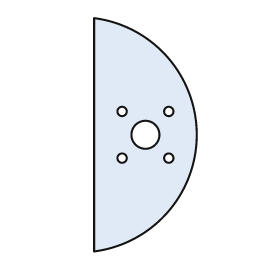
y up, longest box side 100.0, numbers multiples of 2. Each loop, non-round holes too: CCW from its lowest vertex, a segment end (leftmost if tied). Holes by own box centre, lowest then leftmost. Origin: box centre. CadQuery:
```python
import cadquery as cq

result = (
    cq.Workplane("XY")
    .moveTo(-22.0, -50.0)
    .threePointArc((22.0, 0.0), (-22.0, 50.0))
    .close()
    .moveTo(-10.0, -10.0)
    .circle(2.0)
    .moveTo(10.0, -10.0)
    .circle(2.0)
    .moveTo(0.0, 0.0)
    .circle(6.0)
    .moveTo(-10.0, 10.0)
    .circle(2.0)
    .moveTo(10.0, 10.0)
    .circle(2.0)
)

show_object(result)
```